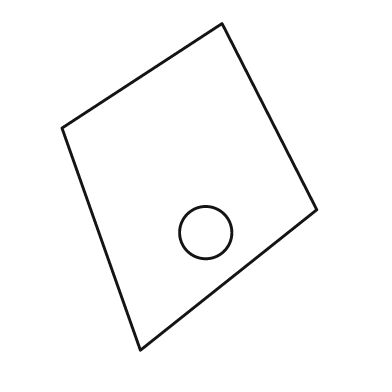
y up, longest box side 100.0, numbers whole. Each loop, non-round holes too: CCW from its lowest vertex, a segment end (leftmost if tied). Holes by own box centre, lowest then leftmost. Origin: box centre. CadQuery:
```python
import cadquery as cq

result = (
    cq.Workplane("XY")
    .moveTo(-15.0, -50.0)
    .lineTo(39.0, -7.0)
    .lineTo(10.0, 50.0)
    .lineTo(-39.0, 18.0)
    .close()
    .moveTo(5.0, -14.0)
    .circle(8.0)
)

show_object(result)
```